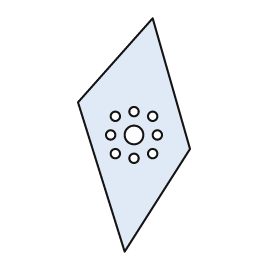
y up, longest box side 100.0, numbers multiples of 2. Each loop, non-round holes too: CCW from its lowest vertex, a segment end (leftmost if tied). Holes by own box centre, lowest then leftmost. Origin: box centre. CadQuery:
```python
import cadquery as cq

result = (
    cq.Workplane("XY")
    .moveTo(-4.0, -50.0)
    .lineTo(24.0, -6.0)
    .lineTo(8.0, 50.0)
    .lineTo(-24.0, 14.0)
    .close()
    .moveTo(0.0, -10.0)
    .circle(2.0)
    .moveTo(-8.0, -8.0)
    .circle(2.0)
    .moveTo(8.0, -8.0)
    .circle(2.0)
    .moveTo(-10.0, 0.0)
    .circle(2.0)
    .moveTo(0.0, 0.0)
    .circle(4.0)
    .moveTo(10.0, 0.0)
    .circle(2.0)
    .moveTo(-8.0, 8.0)
    .circle(2.0)
    .moveTo(8.0, 8.0)
    .circle(2.0)
    .moveTo(0.0, 10.0)
    .circle(2.0)
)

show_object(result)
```